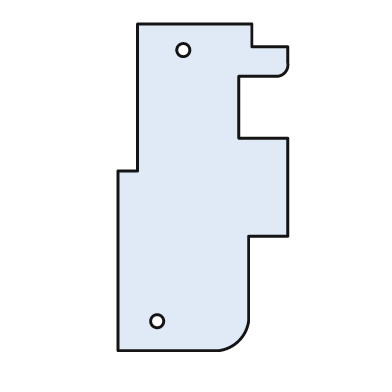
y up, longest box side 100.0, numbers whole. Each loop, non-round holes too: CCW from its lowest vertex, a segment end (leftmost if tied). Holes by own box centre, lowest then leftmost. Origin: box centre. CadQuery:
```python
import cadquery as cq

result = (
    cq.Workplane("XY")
    .moveTo(-26.0, -50.0)
    .lineTo(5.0, -50.0)
    .threePointArc((11.0, -47.0), (14.0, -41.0))
    .lineTo(14.0, -15.0)
    .lineTo(26.0, -15.0)
    .lineTo(26.0, 15.0)
    .lineTo(11.0, 15.0)
    .lineTo(11.0, 34.0)
    .lineTo(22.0, 34.0)
    .threePointArc((25.0, 35.0), (26.0, 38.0))
    .lineTo(26.0, 43.0)
    .lineTo(15.0, 43.0)
    .lineTo(15.0, 50.0)
    .lineTo(-20.0, 50.0)
    .lineTo(-20.0, 5.0)
    .lineTo(-26.0, 5.0)
    .close()
    .moveTo(-14.0, -41.0)
    .circle(2.0)
    .moveTo(-6.0, 42.0)
    .circle(2.0)
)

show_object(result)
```